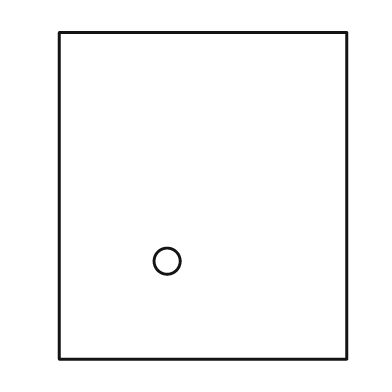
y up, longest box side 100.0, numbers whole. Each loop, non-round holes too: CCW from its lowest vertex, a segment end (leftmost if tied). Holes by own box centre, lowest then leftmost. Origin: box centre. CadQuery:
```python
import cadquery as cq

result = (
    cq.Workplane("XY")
    .moveTo(-44.0, -50.0)
    .lineTo(44.0, -50.0)
    .lineTo(44.0, 50.0)
    .lineTo(-44.0, 50.0)
    .close()
    .moveTo(-11.0, -20.0)
    .circle(4.0)
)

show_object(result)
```